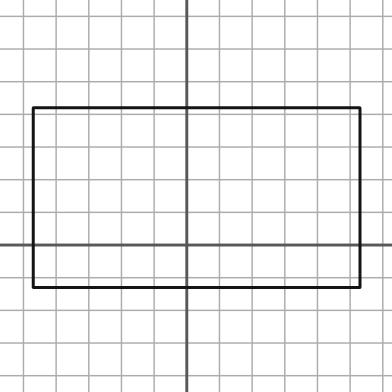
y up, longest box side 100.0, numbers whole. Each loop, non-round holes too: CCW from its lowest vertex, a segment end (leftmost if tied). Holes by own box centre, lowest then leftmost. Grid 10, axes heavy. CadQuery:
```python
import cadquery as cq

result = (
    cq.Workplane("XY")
    .moveTo(-47.0, -13.0)
    .lineTo(53.0, -13.0)
    .lineTo(53.0, 42.0)
    .lineTo(-47.0, 42.0)
    .close()
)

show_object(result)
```